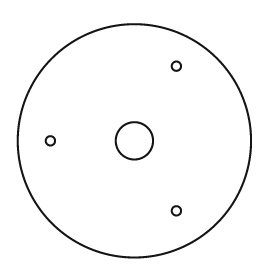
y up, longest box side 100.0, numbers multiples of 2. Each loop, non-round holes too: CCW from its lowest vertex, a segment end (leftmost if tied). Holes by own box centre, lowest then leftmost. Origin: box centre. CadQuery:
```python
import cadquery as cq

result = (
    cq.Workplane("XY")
    .moveTo(0.0, 0.0)
    .circle(50.0)
    .moveTo(18.0, -30.0)
    .circle(2.0)
    .moveTo(-36.0, 0.0)
    .circle(2.0)
    .moveTo(0.0, 0.0)
    .circle(8.0)
    .moveTo(18.0, 32.0)
    .circle(2.0)
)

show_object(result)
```